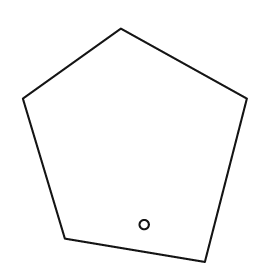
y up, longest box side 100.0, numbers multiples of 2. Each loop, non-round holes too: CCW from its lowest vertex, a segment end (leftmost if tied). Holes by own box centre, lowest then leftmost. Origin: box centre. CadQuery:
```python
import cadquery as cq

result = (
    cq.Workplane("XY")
    .moveTo(30.0, -50.0)
    .lineTo(48.0, 20.0)
    .lineTo(-6.0, 50.0)
    .lineTo(-48.0, 20.0)
    .lineTo(-30.0, -40.0)
    .close()
    .moveTo(4.0, -34.0)
    .circle(2.0)
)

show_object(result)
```